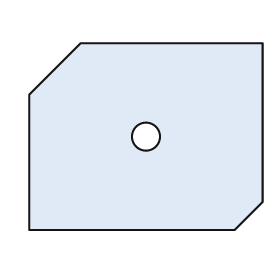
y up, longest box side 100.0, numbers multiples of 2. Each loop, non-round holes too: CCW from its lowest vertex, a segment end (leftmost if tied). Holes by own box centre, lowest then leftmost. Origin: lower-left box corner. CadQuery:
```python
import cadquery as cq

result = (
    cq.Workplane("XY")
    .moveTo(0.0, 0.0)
    .lineTo(88.0, 0.0)
    .lineTo(100.0, 12.0)
    .lineTo(100.0, 80.0)
    .lineTo(22.0, 80.0)
    .lineTo(0.0, 58.0)
    .close()
    .moveTo(50.0, 40.0)
    .circle(6.0)
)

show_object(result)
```